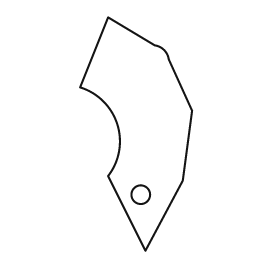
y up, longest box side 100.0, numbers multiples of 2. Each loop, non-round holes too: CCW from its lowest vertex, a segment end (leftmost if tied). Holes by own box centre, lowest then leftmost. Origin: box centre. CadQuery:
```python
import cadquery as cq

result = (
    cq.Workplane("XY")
    .moveTo(4.0, -50.0)
    .lineTo(20.0, -20.0)
    .lineTo(24.0, 10.0)
    .lineTo(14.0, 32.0)
    .threePointArc((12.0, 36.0), (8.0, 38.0))
    .lineTo(-12.0, 50.0)
    .lineTo(-24.0, 20.0)
    .threePointArc((-8.0, 4.0), (-12.0, -18.0))
    .close()
    .moveTo(2.0, -26.0)
    .circle(4.0)
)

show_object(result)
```